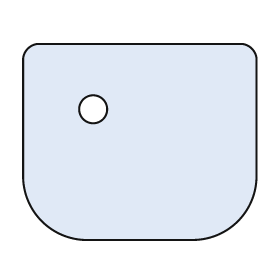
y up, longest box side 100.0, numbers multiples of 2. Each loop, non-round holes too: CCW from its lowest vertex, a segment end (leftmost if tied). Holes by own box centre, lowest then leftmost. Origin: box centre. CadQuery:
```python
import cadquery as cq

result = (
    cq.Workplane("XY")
    .moveTo(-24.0, -42.0)
    .lineTo(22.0, -42.0)
    .threePointArc((42.0, -34.0), (50.0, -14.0))
    .lineTo(50.0, 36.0)
    .threePointArc((48.0, 40.0), (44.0, 42.0))
    .lineTo(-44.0, 42.0)
    .threePointArc((-48.0, 40.0), (-50.0, 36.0))
    .lineTo(-50.0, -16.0)
    .threePointArc((-42.0, -34.0), (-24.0, -42.0))
    .close()
    .moveTo(-20.0, 14.0)
    .circle(6.0)
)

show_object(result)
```